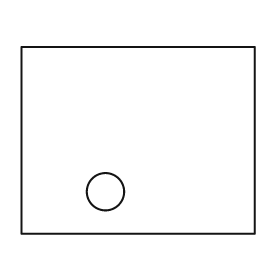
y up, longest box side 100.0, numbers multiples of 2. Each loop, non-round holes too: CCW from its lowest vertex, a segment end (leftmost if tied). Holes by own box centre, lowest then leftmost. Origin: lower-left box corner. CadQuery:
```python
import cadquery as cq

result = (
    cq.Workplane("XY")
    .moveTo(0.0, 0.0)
    .lineTo(100.0, 0.0)
    .lineTo(100.0, 80.0)
    .lineTo(0.0, 80.0)
    .close()
    .moveTo(36.0, 18.0)
    .circle(8.0)
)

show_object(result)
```